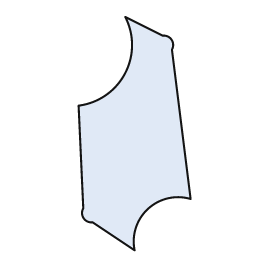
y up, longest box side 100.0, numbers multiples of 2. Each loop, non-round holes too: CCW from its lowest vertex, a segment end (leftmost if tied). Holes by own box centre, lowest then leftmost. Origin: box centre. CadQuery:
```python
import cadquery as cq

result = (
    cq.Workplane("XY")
    .moveTo(0.0, -50.0)
    .threePointArc((6.0, -32.0), (24.0, -28.0))
    .lineTo(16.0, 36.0)
    .threePointArc((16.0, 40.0), (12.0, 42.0))
    .lineTo(-4.0, 50.0)
    .threePointArc((-4.0, 26.0), (-24.0, 12.0))
    .lineTo(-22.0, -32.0)
    .threePointArc((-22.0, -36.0), (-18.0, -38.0))
    .close()
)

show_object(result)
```